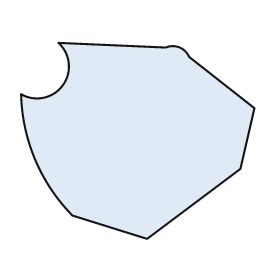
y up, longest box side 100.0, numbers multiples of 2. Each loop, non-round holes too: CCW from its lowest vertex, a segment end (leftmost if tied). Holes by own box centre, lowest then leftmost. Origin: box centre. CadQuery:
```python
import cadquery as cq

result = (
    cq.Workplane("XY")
    .moveTo(4.0, -42.0)
    .lineTo(44.0, -12.0)
    .lineTo(50.0, 14.0)
    .lineTo(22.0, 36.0)
    .threePointArc((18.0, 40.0), (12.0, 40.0))
    .lineTo(-34.0, 42.0)
    .threePointArc((-32.0, 24.0), (-50.0, 20.0))
    .threePointArc((-44.0, -8.0), (-28.0, -32.0))
    .close()
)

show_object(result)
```